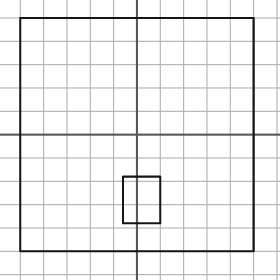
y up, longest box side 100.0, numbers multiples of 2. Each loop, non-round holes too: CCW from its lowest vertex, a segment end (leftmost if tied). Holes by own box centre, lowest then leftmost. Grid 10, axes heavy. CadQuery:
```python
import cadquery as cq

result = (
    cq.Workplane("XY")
    .moveTo(-50.0, -50.0)
    .lineTo(50.0, -50.0)
    .lineTo(50.0, 50.0)
    .lineTo(-50.0, 50.0)
    .close()
    .moveTo(-6.0, -38.0)
    .lineTo(10.0, -38.0)
    .lineTo(10.0, -18.0)
    .lineTo(-6.0, -18.0)
    .close()
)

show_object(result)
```